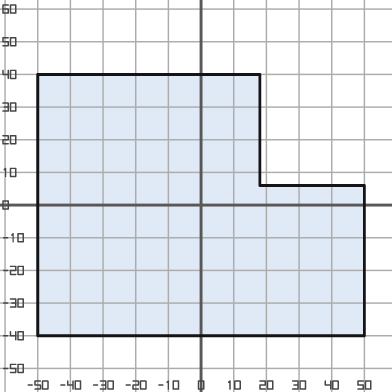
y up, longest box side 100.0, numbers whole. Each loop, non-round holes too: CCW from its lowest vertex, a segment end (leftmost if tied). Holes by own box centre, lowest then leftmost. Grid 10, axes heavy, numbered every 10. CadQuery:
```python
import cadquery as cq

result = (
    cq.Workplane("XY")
    .moveTo(-50.0, -40.0)
    .lineTo(50.0, -40.0)
    .lineTo(50.0, 6.0)
    .lineTo(18.0, 6.0)
    .lineTo(18.0, 40.0)
    .lineTo(-50.0, 40.0)
    .close()
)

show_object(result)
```